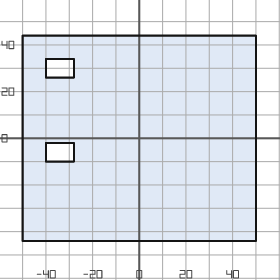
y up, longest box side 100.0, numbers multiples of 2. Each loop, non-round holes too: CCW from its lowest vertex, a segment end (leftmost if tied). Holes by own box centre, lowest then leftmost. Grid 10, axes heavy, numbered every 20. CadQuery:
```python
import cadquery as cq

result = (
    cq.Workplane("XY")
    .moveTo(-50.0, -44.0)
    .lineTo(50.0, -44.0)
    .lineTo(50.0, 44.0)
    .lineTo(-50.0, 44.0)
    .close()
    .moveTo(-40.0, -10.0)
    .lineTo(-28.0, -10.0)
    .lineTo(-28.0, -2.0)
    .lineTo(-40.0, -2.0)
    .close()
    .moveTo(-40.0, 26.0)
    .lineTo(-28.0, 26.0)
    .lineTo(-28.0, 34.0)
    .lineTo(-40.0, 34.0)
    .close()
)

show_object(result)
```